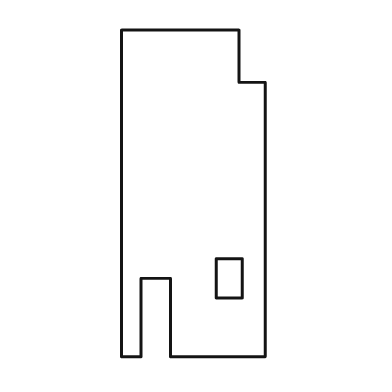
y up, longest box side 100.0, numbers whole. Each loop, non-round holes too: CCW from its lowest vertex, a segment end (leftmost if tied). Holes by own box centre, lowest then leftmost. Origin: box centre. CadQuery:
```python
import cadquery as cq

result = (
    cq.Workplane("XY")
    .moveTo(-22.0, -50.0)
    .lineTo(-16.0, -50.0)
    .lineTo(-16.0, -26.0)
    .lineTo(-7.0, -26.0)
    .lineTo(-7.0, -50.0)
    .lineTo(22.0, -50.0)
    .lineTo(22.0, 34.0)
    .lineTo(14.0, 34.0)
    .lineTo(14.0, 50.0)
    .lineTo(-22.0, 50.0)
    .close()
    .moveTo(7.0, -32.0)
    .lineTo(15.0, -32.0)
    .lineTo(15.0, -20.0)
    .lineTo(7.0, -20.0)
    .close()
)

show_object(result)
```